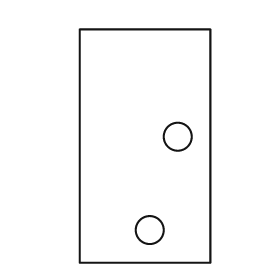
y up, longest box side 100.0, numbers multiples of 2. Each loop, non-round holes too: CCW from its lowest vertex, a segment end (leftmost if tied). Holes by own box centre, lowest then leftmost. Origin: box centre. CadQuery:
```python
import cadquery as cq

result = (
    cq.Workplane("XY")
    .moveTo(-28.0, -50.0)
    .lineTo(28.0, -50.0)
    .lineTo(28.0, 50.0)
    .lineTo(-28.0, 50.0)
    .close()
    .moveTo(2.0, -36.0)
    .circle(6.0)
    .moveTo(14.0, 4.0)
    .circle(6.0)
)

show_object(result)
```